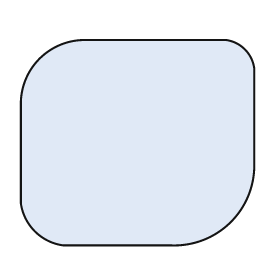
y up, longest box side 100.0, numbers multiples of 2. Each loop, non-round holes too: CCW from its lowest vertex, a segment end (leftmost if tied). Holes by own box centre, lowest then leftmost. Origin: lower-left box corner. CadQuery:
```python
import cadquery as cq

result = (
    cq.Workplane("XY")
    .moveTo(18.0, 0.0)
    .lineTo(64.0, 0.0)
    .threePointArc((90.0, 10.0), (100.0, 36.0))
    .lineTo(100.0, 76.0)
    .threePointArc((96.0, 84.0), (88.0, 88.0))
    .lineTo(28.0, 88.0)
    .threePointArc((8.0, 80.0), (0.0, 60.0))
    .lineTo(0.0, 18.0)
    .threePointArc((6.0, 6.0), (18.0, 0.0))
    .close()
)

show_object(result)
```